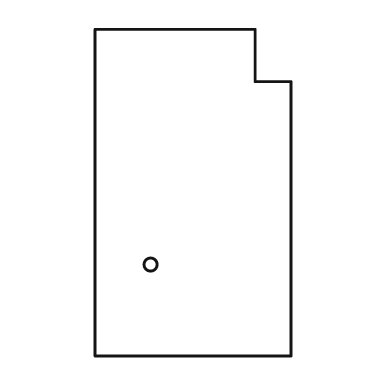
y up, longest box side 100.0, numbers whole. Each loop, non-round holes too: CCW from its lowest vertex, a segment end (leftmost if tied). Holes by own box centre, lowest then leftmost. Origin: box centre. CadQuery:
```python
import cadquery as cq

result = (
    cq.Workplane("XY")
    .moveTo(-30.0, -50.0)
    .lineTo(30.0, -50.0)
    .lineTo(30.0, 34.0)
    .lineTo(19.0, 34.0)
    .lineTo(19.0, 50.0)
    .lineTo(-30.0, 50.0)
    .close()
    .moveTo(-13.0, -22.0)
    .circle(2.0)
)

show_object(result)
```